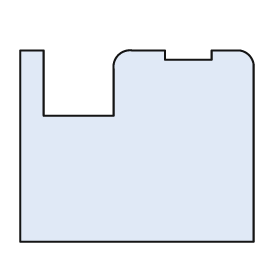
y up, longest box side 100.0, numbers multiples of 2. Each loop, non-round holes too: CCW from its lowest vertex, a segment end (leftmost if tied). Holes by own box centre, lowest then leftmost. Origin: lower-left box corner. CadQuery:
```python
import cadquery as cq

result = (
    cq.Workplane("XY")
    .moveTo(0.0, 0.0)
    .lineTo(100.0, 0.0)
    .lineTo(100.0, 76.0)
    .threePointArc((98.0, 80.0), (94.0, 82.0))
    .lineTo(82.0, 82.0)
    .lineTo(82.0, 78.0)
    .lineTo(62.0, 78.0)
    .lineTo(62.0, 82.0)
    .lineTo(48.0, 82.0)
    .threePointArc((42.0, 80.0), (40.0, 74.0))
    .lineTo(40.0, 54.0)
    .lineTo(10.0, 54.0)
    .lineTo(10.0, 82.0)
    .lineTo(0.0, 82.0)
    .close()
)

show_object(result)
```